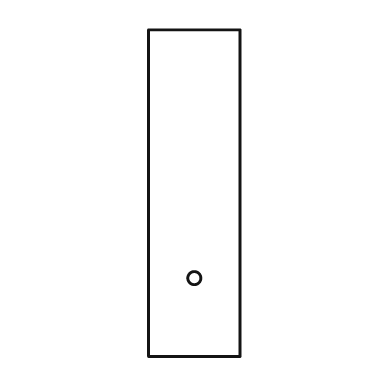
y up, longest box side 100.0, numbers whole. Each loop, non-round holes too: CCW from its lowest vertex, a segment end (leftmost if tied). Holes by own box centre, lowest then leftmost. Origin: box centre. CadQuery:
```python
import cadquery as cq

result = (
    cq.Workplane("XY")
    .moveTo(-14.0, -50.0)
    .lineTo(14.0, -50.0)
    .lineTo(14.0, 50.0)
    .lineTo(-14.0, 50.0)
    .close()
    .moveTo(0.0, -26.0)
    .circle(2.0)
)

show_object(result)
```